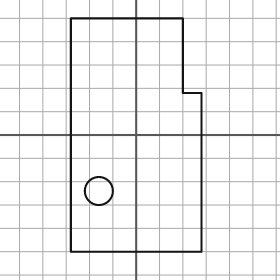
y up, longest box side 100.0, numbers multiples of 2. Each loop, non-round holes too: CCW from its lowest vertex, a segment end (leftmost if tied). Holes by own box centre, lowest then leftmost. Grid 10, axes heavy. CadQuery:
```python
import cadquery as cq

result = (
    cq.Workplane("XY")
    .moveTo(-28.0, -50.0)
    .lineTo(28.0, -50.0)
    .lineTo(28.0, 18.0)
    .lineTo(20.0, 18.0)
    .lineTo(20.0, 50.0)
    .lineTo(-28.0, 50.0)
    .close()
    .moveTo(-16.0, -24.0)
    .circle(6.0)
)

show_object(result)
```